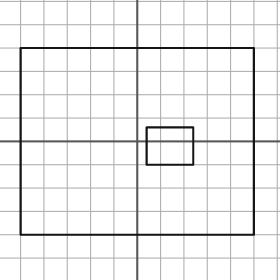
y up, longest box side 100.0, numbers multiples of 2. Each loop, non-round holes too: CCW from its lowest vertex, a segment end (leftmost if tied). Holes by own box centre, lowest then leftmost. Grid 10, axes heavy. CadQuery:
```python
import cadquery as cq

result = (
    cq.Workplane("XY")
    .moveTo(-50.0, -40.0)
    .lineTo(50.0, -40.0)
    .lineTo(50.0, 40.0)
    .lineTo(-50.0, 40.0)
    .close()
    .moveTo(4.0, -10.0)
    .lineTo(24.0, -10.0)
    .lineTo(24.0, 6.0)
    .lineTo(4.0, 6.0)
    .close()
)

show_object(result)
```